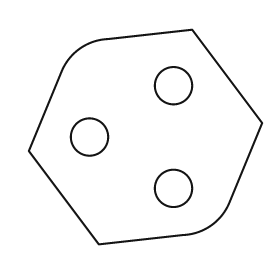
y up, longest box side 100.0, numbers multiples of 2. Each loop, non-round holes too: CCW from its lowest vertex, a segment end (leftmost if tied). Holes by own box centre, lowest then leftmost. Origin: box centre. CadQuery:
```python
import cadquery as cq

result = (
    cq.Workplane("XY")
    .moveTo(-20.0, -46.0)
    .lineTo(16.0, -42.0)
    .threePointArc((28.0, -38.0), (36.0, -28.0))
    .lineTo(50.0, 6.0)
    .lineTo(20.0, 46.0)
    .lineTo(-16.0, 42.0)
    .threePointArc((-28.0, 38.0), (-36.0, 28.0))
    .lineTo(-50.0, -6.0)
    .close()
    .moveTo(12.0, -22.0)
    .circle(8.0)
    .moveTo(-24.0, 0.0)
    .circle(8.0)
    .moveTo(12.0, 22.0)
    .circle(8.0)
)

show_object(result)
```